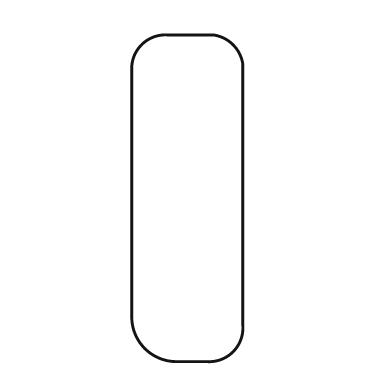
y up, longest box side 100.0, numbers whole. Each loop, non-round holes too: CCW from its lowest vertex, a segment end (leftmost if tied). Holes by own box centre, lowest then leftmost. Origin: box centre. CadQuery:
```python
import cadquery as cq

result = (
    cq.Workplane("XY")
    .moveTo(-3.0, -50.0)
    .lineTo(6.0, -50.0)
    .threePointArc((14.0, -47.0), (17.0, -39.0))
    .lineTo(17.0, 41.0)
    .threePointArc((14.0, 47.0), (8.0, 50.0))
    .lineTo(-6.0, 50.0)
    .threePointArc((-14.0, 47.0), (-17.0, 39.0))
    .lineTo(-17.0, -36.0)
    .threePointArc((-13.0, -46.0), (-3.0, -50.0))
    .close()
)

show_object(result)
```